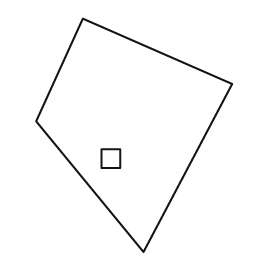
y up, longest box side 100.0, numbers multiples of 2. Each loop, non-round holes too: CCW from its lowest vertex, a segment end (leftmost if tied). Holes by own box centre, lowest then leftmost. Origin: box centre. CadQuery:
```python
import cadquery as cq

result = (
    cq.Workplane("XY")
    .moveTo(4.0, -50.0)
    .lineTo(42.0, 22.0)
    .lineTo(-22.0, 50.0)
    .lineTo(-42.0, 6.0)
    .close()
    .moveTo(-14.0, -14.0)
    .lineTo(-6.0, -14.0)
    .lineTo(-6.0, -6.0)
    .lineTo(-14.0, -6.0)
    .close()
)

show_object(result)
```